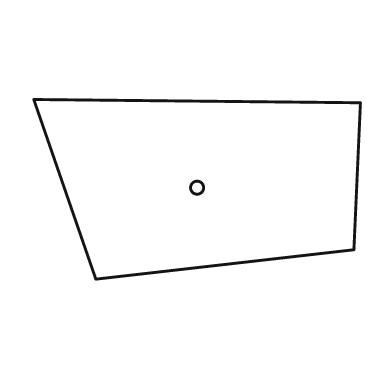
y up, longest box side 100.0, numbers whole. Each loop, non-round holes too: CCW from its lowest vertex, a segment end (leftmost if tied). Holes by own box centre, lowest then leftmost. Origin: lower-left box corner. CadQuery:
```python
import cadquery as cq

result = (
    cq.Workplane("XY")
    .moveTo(19.0, 0.0)
    .lineTo(98.0, 9.0)
    .lineTo(100.0, 54.0)
    .lineTo(0.0, 55.0)
    .close()
    .moveTo(50.0, 28.0)
    .circle(2.0)
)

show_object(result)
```